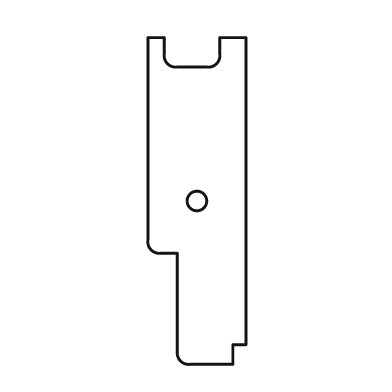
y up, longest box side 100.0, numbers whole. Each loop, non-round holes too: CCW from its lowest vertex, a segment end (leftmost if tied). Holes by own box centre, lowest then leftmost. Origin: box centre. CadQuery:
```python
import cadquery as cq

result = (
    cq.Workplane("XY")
    .moveTo(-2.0, -50.0)
    .lineTo(11.0, -50.0)
    .lineTo(11.0, -44.0)
    .lineTo(15.0, -44.0)
    .lineTo(15.0, 50.0)
    .lineTo(7.0, 50.0)
    .lineTo(7.0, 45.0)
    .threePointArc((6.0, 42.0), (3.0, 41.0))
    .lineTo(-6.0, 41.0)
    .threePointArc((-9.0, 42.0), (-10.0, 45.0))
    .lineTo(-10.0, 50.0)
    .lineTo(-15.0, 50.0)
    .lineTo(-15.0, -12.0)
    .threePointArc((-14.0, -15.0), (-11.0, -16.0))
    .lineTo(-6.0, -16.0)
    .lineTo(-6.0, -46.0)
    .threePointArc((-5.0, -49.0), (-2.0, -50.0))
    .close()
    .moveTo(0.0, 0.0)
    .circle(3.0)
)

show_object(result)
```